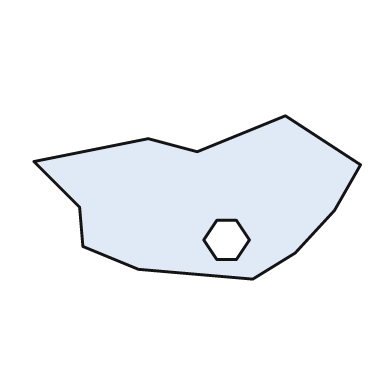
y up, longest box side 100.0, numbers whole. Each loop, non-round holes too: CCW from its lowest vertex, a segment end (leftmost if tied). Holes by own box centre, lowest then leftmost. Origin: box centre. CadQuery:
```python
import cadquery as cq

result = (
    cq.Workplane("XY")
    .moveTo(17.0, -25.0)
    .lineTo(30.0, -17.0)
    .lineTo(42.0, -4.0)
    .lineTo(50.0, 10.0)
    .lineTo(27.0, 25.0)
    .lineTo(0.0, 14.0)
    .lineTo(-15.0, 18.0)
    .lineTo(-50.0, 11.0)
    .lineTo(-36.0, -3.0)
    .lineTo(-35.0, -15.0)
    .lineTo(-18.0, -22.0)
    .close()
    .moveTo(6.0, -19.0)
    .lineTo(12.0, -19.0)
    .lineTo(16.0, -13.0)
    .lineTo(12.0, -7.0)
    .lineTo(6.0, -7.0)
    .lineTo(2.0, -13.0)
    .close()
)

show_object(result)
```